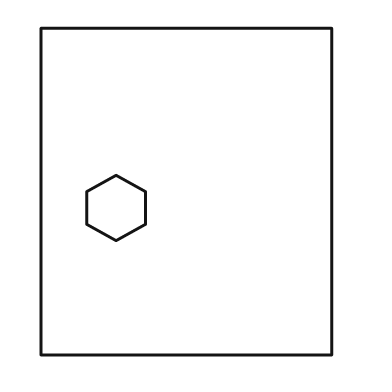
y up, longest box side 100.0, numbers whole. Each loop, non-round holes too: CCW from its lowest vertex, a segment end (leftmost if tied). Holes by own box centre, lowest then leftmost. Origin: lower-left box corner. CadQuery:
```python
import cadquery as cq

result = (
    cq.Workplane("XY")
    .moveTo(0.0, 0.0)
    .lineTo(89.0, 0.0)
    .lineTo(89.0, 100.0)
    .lineTo(0.0, 100.0)
    .close()
    .moveTo(23.0, 35.0)
    .lineTo(32.0, 40.0)
    .lineTo(32.0, 50.0)
    .lineTo(23.0, 55.0)
    .lineTo(14.0, 50.0)
    .lineTo(14.0, 40.0)
    .close()
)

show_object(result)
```